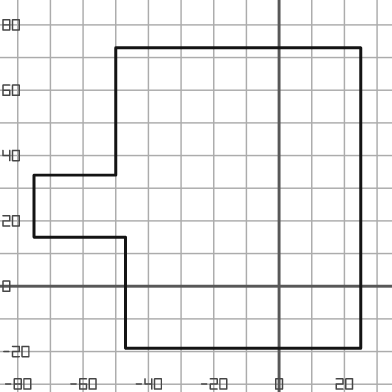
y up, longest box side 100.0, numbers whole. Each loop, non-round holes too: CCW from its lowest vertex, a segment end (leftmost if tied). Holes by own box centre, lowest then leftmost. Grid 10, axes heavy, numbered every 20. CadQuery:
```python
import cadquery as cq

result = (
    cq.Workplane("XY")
    .moveTo(-47.0, -19.0)
    .lineTo(25.0, -19.0)
    .lineTo(25.0, 73.0)
    .lineTo(-50.0, 73.0)
    .lineTo(-50.0, 34.0)
    .lineTo(-75.0, 34.0)
    .lineTo(-75.0, 15.0)
    .lineTo(-47.0, 15.0)
    .close()
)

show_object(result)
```